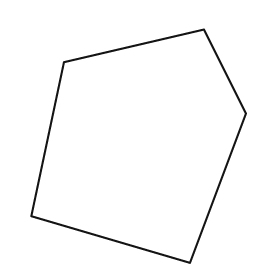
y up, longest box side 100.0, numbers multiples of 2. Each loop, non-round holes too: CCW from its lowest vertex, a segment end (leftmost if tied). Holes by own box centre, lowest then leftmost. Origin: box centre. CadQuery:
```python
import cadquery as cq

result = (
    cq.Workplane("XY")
    .moveTo(22.0, -50.0)
    .lineTo(46.0, 14.0)
    .lineTo(28.0, 50.0)
    .lineTo(-32.0, 36.0)
    .lineTo(-46.0, -30.0)
    .close()
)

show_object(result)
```